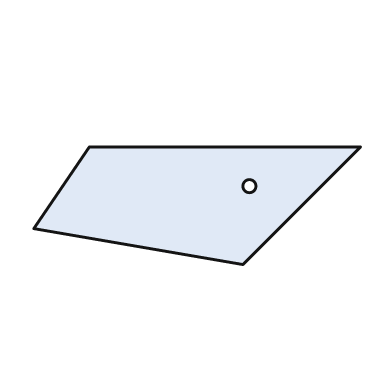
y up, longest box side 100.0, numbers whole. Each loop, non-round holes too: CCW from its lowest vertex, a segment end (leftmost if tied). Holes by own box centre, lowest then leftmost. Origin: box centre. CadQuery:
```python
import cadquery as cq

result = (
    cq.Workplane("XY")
    .moveTo(14.0, -18.0)
    .lineTo(50.0, 18.0)
    .lineTo(-33.0, 18.0)
    .lineTo(-50.0, -7.0)
    .close()
    .moveTo(16.0, 6.0)
    .circle(2.0)
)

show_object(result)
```